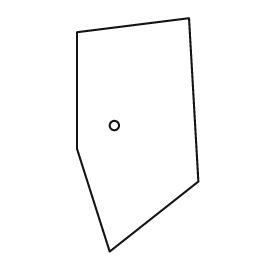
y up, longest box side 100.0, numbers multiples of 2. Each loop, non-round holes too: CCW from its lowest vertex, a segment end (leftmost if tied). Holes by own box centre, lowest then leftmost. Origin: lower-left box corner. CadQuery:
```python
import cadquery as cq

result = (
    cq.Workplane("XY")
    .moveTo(14.0, 0.0)
    .lineTo(52.0, 30.0)
    .lineTo(48.0, 100.0)
    .lineTo(0.0, 94.0)
    .lineTo(0.0, 44.0)
    .close()
    .moveTo(16.0, 54.0)
    .circle(2.0)
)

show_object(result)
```